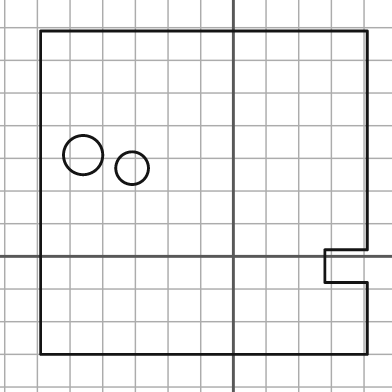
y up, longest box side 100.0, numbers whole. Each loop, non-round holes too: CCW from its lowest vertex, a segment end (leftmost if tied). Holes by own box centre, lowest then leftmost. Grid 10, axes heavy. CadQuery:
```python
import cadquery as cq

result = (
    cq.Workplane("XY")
    .moveTo(-59.0, -30.0)
    .lineTo(41.0, -30.0)
    .lineTo(41.0, -8.0)
    .lineTo(28.0, -8.0)
    .lineTo(28.0, 2.0)
    .lineTo(41.0, 2.0)
    .lineTo(41.0, 69.0)
    .lineTo(-59.0, 69.0)
    .close()
    .moveTo(-31.0, 27.0)
    .circle(5.0)
    .moveTo(-46.0, 31.0)
    .circle(6.0)
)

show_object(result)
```